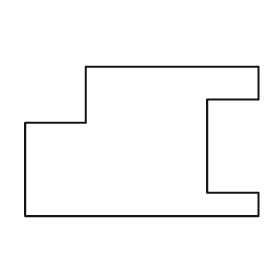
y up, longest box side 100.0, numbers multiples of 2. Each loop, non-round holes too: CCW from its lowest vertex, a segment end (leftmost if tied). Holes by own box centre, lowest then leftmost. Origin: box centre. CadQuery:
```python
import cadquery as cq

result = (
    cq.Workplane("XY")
    .moveTo(-50.0, -32.0)
    .lineTo(50.0, -32.0)
    .lineTo(50.0, -22.0)
    .lineTo(28.0, -22.0)
    .lineTo(28.0, 18.0)
    .lineTo(50.0, 18.0)
    .lineTo(50.0, 32.0)
    .lineTo(-24.0, 32.0)
    .lineTo(-24.0, 8.0)
    .lineTo(-50.0, 8.0)
    .close()
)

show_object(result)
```